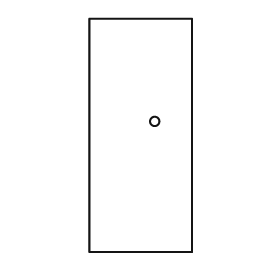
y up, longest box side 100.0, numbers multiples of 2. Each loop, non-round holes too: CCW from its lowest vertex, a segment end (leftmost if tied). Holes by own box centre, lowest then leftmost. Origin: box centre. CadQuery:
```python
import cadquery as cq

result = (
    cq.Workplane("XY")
    .moveTo(-22.0, -50.0)
    .lineTo(22.0, -50.0)
    .lineTo(22.0, 50.0)
    .lineTo(-22.0, 50.0)
    .close()
    .moveTo(6.0, 6.0)
    .circle(2.0)
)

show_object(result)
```